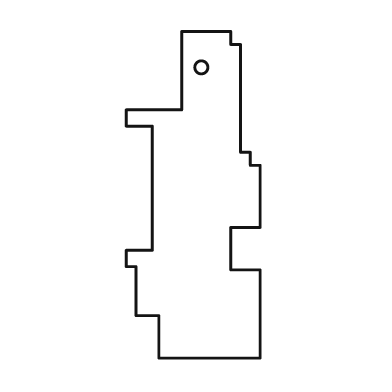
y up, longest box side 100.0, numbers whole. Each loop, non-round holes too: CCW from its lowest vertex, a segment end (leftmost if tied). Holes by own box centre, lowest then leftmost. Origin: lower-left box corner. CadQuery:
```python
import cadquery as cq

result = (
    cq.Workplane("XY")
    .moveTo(10.0, 0.0)
    .lineTo(41.0, 0.0)
    .lineTo(41.0, 27.0)
    .lineTo(32.0, 27.0)
    .lineTo(32.0, 40.0)
    .lineTo(41.0, 40.0)
    .lineTo(41.0, 59.0)
    .lineTo(38.0, 59.0)
    .lineTo(38.0, 63.0)
    .lineTo(35.0, 63.0)
    .lineTo(35.0, 96.0)
    .lineTo(32.0, 96.0)
    .lineTo(32.0, 100.0)
    .lineTo(17.0, 100.0)
    .lineTo(17.0, 76.0)
    .lineTo(0.0, 76.0)
    .lineTo(0.0, 71.0)
    .lineTo(8.0, 71.0)
    .lineTo(8.0, 33.0)
    .lineTo(0.0, 33.0)
    .lineTo(0.0, 28.0)
    .lineTo(3.0, 28.0)
    .lineTo(3.0, 13.0)
    .lineTo(10.0, 13.0)
    .close()
    .moveTo(23.0, 89.0)
    .circle(2.0)
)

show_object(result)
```